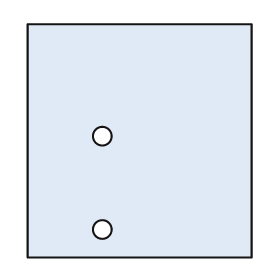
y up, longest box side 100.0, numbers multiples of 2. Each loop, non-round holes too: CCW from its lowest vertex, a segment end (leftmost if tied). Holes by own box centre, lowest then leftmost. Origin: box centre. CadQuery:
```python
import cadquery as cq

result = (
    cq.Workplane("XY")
    .moveTo(-48.0, -50.0)
    .lineTo(48.0, -50.0)
    .lineTo(48.0, 50.0)
    .lineTo(-48.0, 50.0)
    .close()
    .moveTo(-16.0, -38.0)
    .circle(4.0)
    .moveTo(-16.0, 2.0)
    .circle(4.0)
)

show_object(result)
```